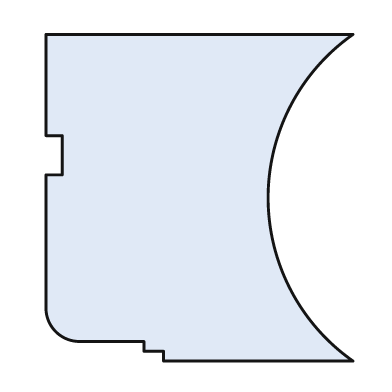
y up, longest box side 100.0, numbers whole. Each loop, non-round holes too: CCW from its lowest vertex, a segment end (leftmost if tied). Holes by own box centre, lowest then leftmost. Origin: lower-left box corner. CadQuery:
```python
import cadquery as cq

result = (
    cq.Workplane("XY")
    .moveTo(36.0, 0.0)
    .lineTo(94.0, 0.0)
    .threePointArc((68.0, 50.0), (94.0, 100.0))
    .lineTo(0.0, 100.0)
    .lineTo(0.0, 69.0)
    .lineTo(5.0, 69.0)
    .lineTo(5.0, 57.0)
    .lineTo(0.0, 57.0)
    .lineTo(0.0, 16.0)
    .threePointArc((3.0, 9.0), (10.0, 6.0))
    .lineTo(30.0, 6.0)
    .lineTo(30.0, 3.0)
    .lineTo(36.0, 3.0)
    .close()
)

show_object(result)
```